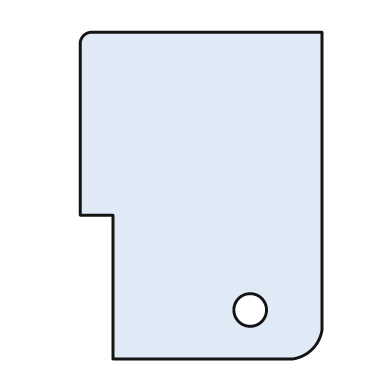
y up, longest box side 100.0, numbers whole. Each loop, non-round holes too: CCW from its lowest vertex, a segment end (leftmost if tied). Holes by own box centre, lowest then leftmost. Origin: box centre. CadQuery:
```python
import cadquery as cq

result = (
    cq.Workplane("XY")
    .moveTo(-27.0, -50.0)
    .lineTo(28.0, -50.0)
    .threePointArc((34.0, -47.0), (37.0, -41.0))
    .lineTo(37.0, 50.0)
    .lineTo(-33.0, 50.0)
    .threePointArc((-36.0, 49.0), (-37.0, 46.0))
    .lineTo(-37.0, -6.0)
    .lineTo(-27.0, -6.0)
    .close()
    .moveTo(15.0, -35.0)
    .circle(5.0)
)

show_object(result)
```